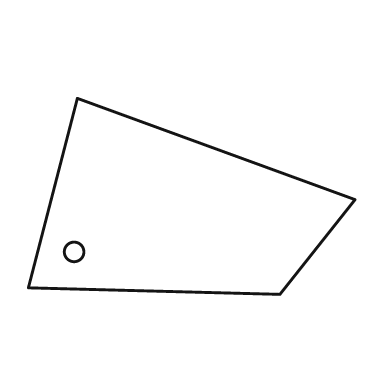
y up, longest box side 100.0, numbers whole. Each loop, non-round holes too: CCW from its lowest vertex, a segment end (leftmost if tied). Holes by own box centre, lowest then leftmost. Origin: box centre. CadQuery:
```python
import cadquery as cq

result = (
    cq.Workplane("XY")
    .moveTo(27.0, -30.0)
    .lineTo(50.0, -1.0)
    .lineTo(-35.0, 30.0)
    .lineTo(-50.0, -28.0)
    .close()
    .moveTo(-36.0, -17.0)
    .circle(3.0)
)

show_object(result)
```